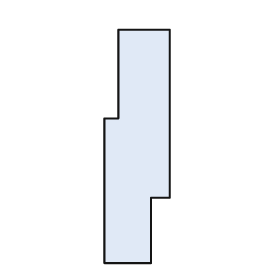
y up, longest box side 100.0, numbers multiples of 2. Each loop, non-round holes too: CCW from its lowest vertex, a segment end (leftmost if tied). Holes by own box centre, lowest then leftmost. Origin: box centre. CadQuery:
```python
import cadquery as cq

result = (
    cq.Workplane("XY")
    .moveTo(-14.0, -50.0)
    .lineTo(6.0, -50.0)
    .lineTo(6.0, -22.0)
    .lineTo(14.0, -22.0)
    .lineTo(14.0, 50.0)
    .lineTo(-8.0, 50.0)
    .lineTo(-8.0, 12.0)
    .lineTo(-14.0, 12.0)
    .close()
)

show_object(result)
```